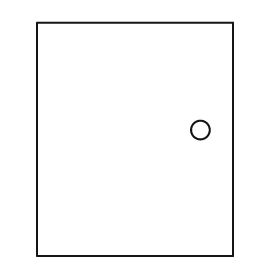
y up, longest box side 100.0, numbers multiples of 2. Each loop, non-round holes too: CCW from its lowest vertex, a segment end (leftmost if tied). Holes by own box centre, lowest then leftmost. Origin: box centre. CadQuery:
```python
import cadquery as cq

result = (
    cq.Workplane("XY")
    .moveTo(-42.0, -50.0)
    .lineTo(42.0, -50.0)
    .lineTo(42.0, 50.0)
    .lineTo(-42.0, 50.0)
    .close()
    .moveTo(28.0, 4.0)
    .circle(4.0)
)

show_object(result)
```